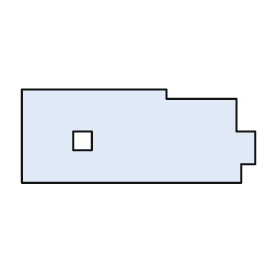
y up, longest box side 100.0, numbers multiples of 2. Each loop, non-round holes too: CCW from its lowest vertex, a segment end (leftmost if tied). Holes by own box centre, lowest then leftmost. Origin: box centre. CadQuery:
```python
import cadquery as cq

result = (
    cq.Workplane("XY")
    .moveTo(-50.0, -20.0)
    .lineTo(44.0, -20.0)
    .lineTo(44.0, -12.0)
    .lineTo(50.0, -12.0)
    .lineTo(50.0, 2.0)
    .lineTo(42.0, 2.0)
    .lineTo(42.0, 16.0)
    .lineTo(12.0, 16.0)
    .lineTo(12.0, 20.0)
    .lineTo(-50.0, 20.0)
    .close()
    .moveTo(-28.0, -6.0)
    .lineTo(-20.0, -6.0)
    .lineTo(-20.0, 2.0)
    .lineTo(-28.0, 2.0)
    .close()
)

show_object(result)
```